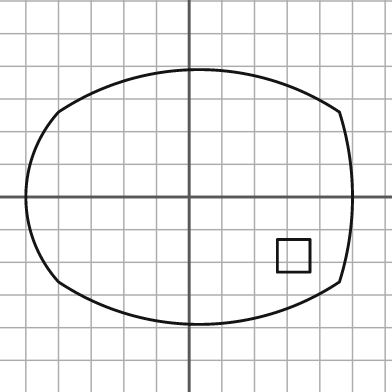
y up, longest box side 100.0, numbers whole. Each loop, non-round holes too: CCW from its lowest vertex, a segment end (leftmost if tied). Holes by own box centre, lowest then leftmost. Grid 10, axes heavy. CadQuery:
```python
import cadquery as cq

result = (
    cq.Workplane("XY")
    .moveTo(-40.0, -26.0)
    .threePointArc((3.0, -39.0), (46.0, -26.0))
    .threePointArc((50.0, 0.0), (46.0, 26.0))
    .threePointArc((3.0, 39.0), (-40.0, 26.0))
    .threePointArc((-50.0, 0.0), (-40.0, -26.0))
    .close()
    .moveTo(27.0, -23.0)
    .lineTo(37.0, -23.0)
    .lineTo(37.0, -13.0)
    .lineTo(27.0, -13.0)
    .close()
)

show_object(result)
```